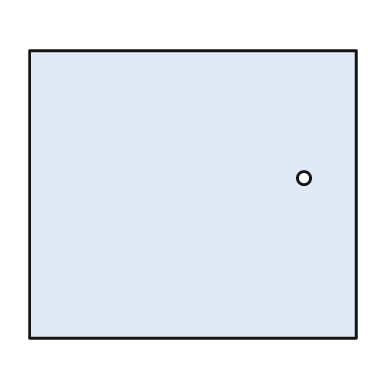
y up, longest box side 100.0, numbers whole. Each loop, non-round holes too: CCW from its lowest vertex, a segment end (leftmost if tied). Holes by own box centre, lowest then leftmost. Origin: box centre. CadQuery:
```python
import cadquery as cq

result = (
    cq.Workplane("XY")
    .moveTo(-50.0, -44.0)
    .lineTo(50.0, -44.0)
    .lineTo(50.0, 44.0)
    .lineTo(-50.0, 44.0)
    .close()
    .moveTo(34.0, 5.0)
    .circle(2.0)
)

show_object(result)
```